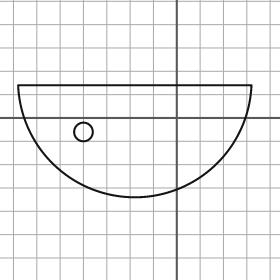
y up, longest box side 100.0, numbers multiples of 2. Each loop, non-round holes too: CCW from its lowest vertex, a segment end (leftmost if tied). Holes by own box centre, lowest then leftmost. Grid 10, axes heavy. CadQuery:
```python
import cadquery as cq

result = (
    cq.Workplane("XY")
    .moveTo(-68.0, 14.0)
    .threePointArc((-18.0, -34.0), (32.0, 14.0))
    .close()
    .moveTo(-40.0, -6.0)
    .circle(4.0)
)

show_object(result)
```